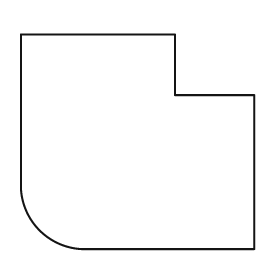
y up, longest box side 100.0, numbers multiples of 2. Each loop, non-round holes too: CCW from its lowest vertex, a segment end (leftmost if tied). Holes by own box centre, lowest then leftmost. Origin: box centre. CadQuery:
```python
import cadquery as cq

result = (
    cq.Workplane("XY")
    .moveTo(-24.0, -46.0)
    .lineTo(50.0, -46.0)
    .lineTo(50.0, 20.0)
    .lineTo(16.0, 20.0)
    .lineTo(16.0, 46.0)
    .lineTo(-50.0, 46.0)
    .lineTo(-50.0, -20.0)
    .threePointArc((-42.0, -38.0), (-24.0, -46.0))
    .close()
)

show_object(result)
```